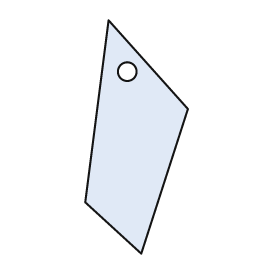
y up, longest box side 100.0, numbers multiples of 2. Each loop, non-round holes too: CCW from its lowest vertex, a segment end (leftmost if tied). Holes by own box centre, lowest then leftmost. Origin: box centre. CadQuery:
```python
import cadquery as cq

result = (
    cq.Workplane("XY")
    .moveTo(2.0, -50.0)
    .lineTo(22.0, 12.0)
    .lineTo(-12.0, 50.0)
    .lineTo(-22.0, -28.0)
    .close()
    .moveTo(-4.0, 28.0)
    .circle(4.0)
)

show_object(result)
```